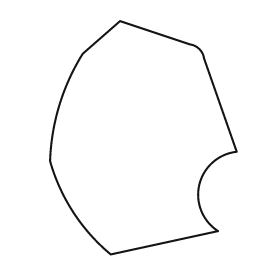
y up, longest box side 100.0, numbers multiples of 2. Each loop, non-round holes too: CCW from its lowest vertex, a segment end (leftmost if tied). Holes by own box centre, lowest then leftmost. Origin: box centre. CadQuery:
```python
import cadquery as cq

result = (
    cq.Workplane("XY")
    .moveTo(-14.0, -50.0)
    .lineTo(32.0, -40.0)
    .threePointArc((24.0, -20.0), (40.0, -6.0))
    .lineTo(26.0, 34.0)
    .threePointArc((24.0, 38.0), (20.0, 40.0))
    .lineTo(-10.0, 50.0)
    .lineTo(-26.0, 36.0)
    .threePointArc((-36.0, 14.0), (-40.0, -10.0))
    .threePointArc((-30.0, -32.0), (-14.0, -50.0))
    .close()
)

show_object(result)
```